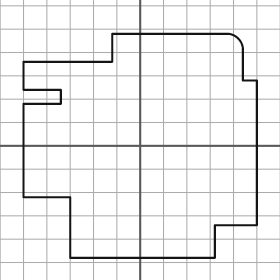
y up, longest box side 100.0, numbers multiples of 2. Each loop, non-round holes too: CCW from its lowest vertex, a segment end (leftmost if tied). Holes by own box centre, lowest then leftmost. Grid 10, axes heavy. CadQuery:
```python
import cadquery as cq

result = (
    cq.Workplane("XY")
    .moveTo(-30.0, -48.0)
    .lineTo(32.0, -48.0)
    .lineTo(32.0, -34.0)
    .lineTo(50.0, -34.0)
    .lineTo(50.0, 28.0)
    .lineTo(44.0, 28.0)
    .lineTo(44.0, 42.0)
    .threePointArc((42.0, 46.0), (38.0, 48.0))
    .lineTo(-12.0, 48.0)
    .lineTo(-12.0, 36.0)
    .lineTo(-50.0, 36.0)
    .lineTo(-50.0, 24.0)
    .lineTo(-34.0, 24.0)
    .lineTo(-34.0, 18.0)
    .lineTo(-50.0, 18.0)
    .lineTo(-50.0, -22.0)
    .lineTo(-30.0, -22.0)
    .close()
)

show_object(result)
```